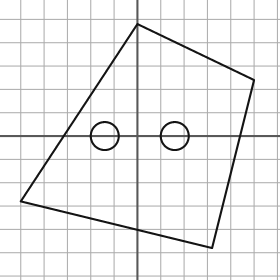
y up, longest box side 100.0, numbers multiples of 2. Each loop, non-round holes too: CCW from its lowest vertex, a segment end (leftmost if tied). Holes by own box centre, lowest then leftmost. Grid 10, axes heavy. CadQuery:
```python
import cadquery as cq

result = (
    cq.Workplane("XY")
    .moveTo(32.0, -48.0)
    .lineTo(50.0, 24.0)
    .lineTo(0.0, 48.0)
    .lineTo(-50.0, -28.0)
    .close()
    .moveTo(-14.0, 0.0)
    .circle(6.0)
    .moveTo(16.0, 0.0)
    .circle(6.0)
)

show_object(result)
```